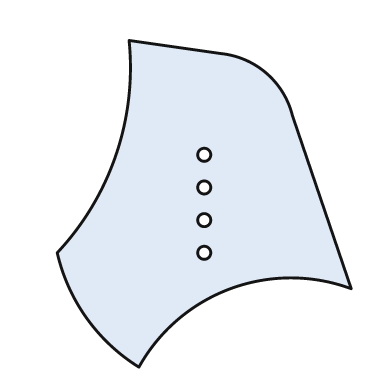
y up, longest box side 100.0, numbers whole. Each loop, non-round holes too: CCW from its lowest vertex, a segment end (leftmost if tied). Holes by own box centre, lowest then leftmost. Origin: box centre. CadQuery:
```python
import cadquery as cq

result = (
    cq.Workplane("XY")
    .moveTo(-20.0, -50.0)
    .threePointArc((8.0, -26.0), (45.0, -26.0))
    .lineTo(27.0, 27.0)
    .threePointArc((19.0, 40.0), (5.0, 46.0))
    .lineTo(-23.0, 50.0)
    .threePointArc((-27.0, 15.0), (-45.0, -15.0))
    .threePointArc((-36.0, -35.0), (-20.0, -50.0))
    .close()
    .moveTo(0.0, -15.0)
    .circle(2.0)
    .moveTo(0.0, -5.0)
    .circle(2.0)
    .moveTo(0.0, 5.0)
    .circle(2.0)
    .moveTo(0.0, 15.0)
    .circle(2.0)
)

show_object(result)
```